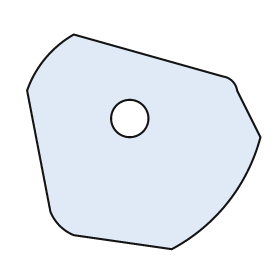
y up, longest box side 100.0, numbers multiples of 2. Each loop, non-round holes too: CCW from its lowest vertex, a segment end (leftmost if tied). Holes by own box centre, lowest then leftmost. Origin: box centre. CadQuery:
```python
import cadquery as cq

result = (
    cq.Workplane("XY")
    .moveTo(12.0, -46.0)
    .threePointArc((36.0, -26.0), (50.0, 2.0))
    .lineTo(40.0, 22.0)
    .threePointArc((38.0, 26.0), (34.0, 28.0))
    .lineTo(-30.0, 46.0)
    .threePointArc((-42.0, 36.0), (-50.0, 22.0))
    .lineTo(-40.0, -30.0)
    .threePointArc((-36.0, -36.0), (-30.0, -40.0))
    .close()
    .moveTo(-6.0, 10.0)
    .circle(8.0)
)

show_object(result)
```